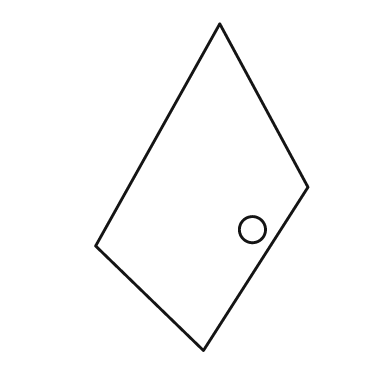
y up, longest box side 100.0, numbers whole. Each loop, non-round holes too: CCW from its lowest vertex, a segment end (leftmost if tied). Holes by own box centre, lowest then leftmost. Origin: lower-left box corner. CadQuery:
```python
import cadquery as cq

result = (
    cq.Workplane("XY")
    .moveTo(33.0, 0.0)
    .lineTo(65.0, 50.0)
    .lineTo(38.0, 100.0)
    .lineTo(0.0, 32.0)
    .close()
    .moveTo(48.0, 37.0)
    .circle(4.0)
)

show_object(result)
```